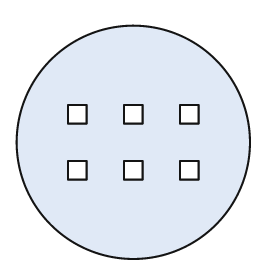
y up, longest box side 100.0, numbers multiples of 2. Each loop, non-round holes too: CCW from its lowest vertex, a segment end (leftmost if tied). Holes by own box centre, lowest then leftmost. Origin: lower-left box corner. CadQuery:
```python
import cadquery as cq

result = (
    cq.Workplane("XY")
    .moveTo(50.0, 50.0)
    .circle(50.0)
    .moveTo(22.0, 34.0)
    .lineTo(30.0, 34.0)
    .lineTo(30.0, 42.0)
    .lineTo(22.0, 42.0)
    .close()
    .moveTo(46.0, 34.0)
    .lineTo(54.0, 34.0)
    .lineTo(54.0, 42.0)
    .lineTo(46.0, 42.0)
    .close()
    .moveTo(70.0, 34.0)
    .lineTo(78.0, 34.0)
    .lineTo(78.0, 42.0)
    .lineTo(70.0, 42.0)
    .close()
    .moveTo(22.0, 58.0)
    .lineTo(30.0, 58.0)
    .lineTo(30.0, 66.0)
    .lineTo(22.0, 66.0)
    .close()
    .moveTo(46.0, 58.0)
    .lineTo(54.0, 58.0)
    .lineTo(54.0, 66.0)
    .lineTo(46.0, 66.0)
    .close()
    .moveTo(70.0, 58.0)
    .lineTo(78.0, 58.0)
    .lineTo(78.0, 66.0)
    .lineTo(70.0, 66.0)
    .close()
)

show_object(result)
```